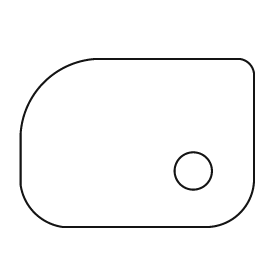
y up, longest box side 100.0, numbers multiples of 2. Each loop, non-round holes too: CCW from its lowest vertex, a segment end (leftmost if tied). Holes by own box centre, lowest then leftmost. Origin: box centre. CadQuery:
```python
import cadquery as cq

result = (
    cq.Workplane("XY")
    .moveTo(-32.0, -36.0)
    .lineTo(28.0, -36.0)
    .threePointArc((44.0, -30.0), (50.0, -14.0))
    .lineTo(50.0, 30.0)
    .threePointArc((48.0, 34.0), (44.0, 36.0))
    .lineTo(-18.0, 36.0)
    .threePointArc((-40.0, 26.0), (-50.0, 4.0))
    .lineTo(-50.0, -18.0)
    .threePointArc((-44.0, -30.0), (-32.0, -36.0))
    .close()
    .moveTo(24.0, -12.0)
    .circle(8.0)
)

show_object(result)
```